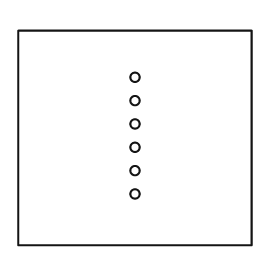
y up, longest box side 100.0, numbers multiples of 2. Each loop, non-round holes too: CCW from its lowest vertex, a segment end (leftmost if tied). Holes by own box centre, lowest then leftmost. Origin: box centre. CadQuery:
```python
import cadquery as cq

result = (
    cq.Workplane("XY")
    .moveTo(-50.0, -46.0)
    .lineTo(50.0, -46.0)
    .lineTo(50.0, 46.0)
    .lineTo(-50.0, 46.0)
    .close()
    .moveTo(0.0, -24.0)
    .circle(2.0)
    .moveTo(0.0, -14.0)
    .circle(2.0)
    .moveTo(0.0, -4.0)
    .circle(2.0)
    .moveTo(0.0, 6.0)
    .circle(2.0)
    .moveTo(0.0, 16.0)
    .circle(2.0)
    .moveTo(0.0, 26.0)
    .circle(2.0)
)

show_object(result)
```